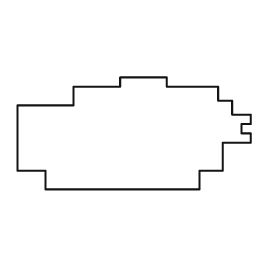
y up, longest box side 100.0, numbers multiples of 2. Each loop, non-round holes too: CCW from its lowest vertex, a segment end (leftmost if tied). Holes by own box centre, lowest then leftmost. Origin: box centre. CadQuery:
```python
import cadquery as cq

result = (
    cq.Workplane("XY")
    .moveTo(-38.0, -24.0)
    .lineTo(28.0, -24.0)
    .lineTo(28.0, -16.0)
    .lineTo(38.0, -16.0)
    .lineTo(38.0, -4.0)
    .lineTo(50.0, -4.0)
    .lineTo(50.0, 0.0)
    .lineTo(46.0, 0.0)
    .lineTo(46.0, 4.0)
    .lineTo(50.0, 4.0)
    .lineTo(50.0, 8.0)
    .lineTo(42.0, 8.0)
    .lineTo(42.0, 14.0)
    .lineTo(36.0, 14.0)
    .lineTo(36.0, 20.0)
    .lineTo(14.0, 20.0)
    .lineTo(14.0, 24.0)
    .lineTo(-6.0, 24.0)
    .lineTo(-6.0, 20.0)
    .lineTo(-26.0, 20.0)
    .lineTo(-26.0, 12.0)
    .lineTo(-50.0, 12.0)
    .lineTo(-50.0, -16.0)
    .lineTo(-38.0, -16.0)
    .close()
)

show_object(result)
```